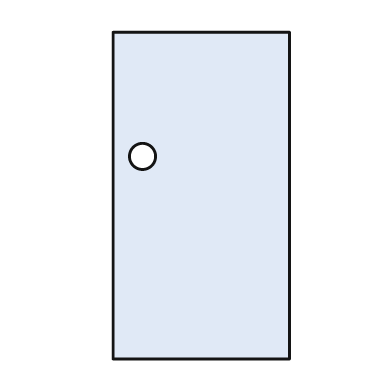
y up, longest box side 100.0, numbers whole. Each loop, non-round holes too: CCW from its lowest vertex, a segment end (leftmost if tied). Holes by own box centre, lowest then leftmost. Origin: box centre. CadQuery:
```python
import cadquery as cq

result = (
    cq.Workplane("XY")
    .moveTo(-27.0, -50.0)
    .lineTo(27.0, -50.0)
    .lineTo(27.0, 50.0)
    .lineTo(-27.0, 50.0)
    .close()
    .moveTo(-18.0, 12.0)
    .circle(4.0)
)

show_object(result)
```